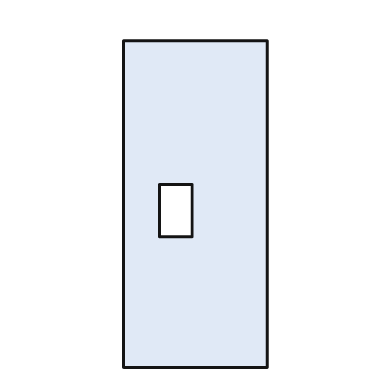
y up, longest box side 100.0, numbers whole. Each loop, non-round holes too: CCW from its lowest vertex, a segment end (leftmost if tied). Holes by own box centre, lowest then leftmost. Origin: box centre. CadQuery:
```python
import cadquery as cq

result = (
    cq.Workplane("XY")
    .moveTo(-22.0, -50.0)
    .lineTo(22.0, -50.0)
    .lineTo(22.0, 50.0)
    .lineTo(-22.0, 50.0)
    .close()
    .moveTo(-11.0, -10.0)
    .lineTo(-1.0, -10.0)
    .lineTo(-1.0, 6.0)
    .lineTo(-11.0, 6.0)
    .close()
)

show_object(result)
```